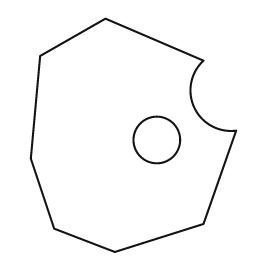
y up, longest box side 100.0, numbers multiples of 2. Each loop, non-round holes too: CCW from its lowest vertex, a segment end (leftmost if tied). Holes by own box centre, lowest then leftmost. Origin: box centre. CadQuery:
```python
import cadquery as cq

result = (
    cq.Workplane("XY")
    .moveTo(-8.0, -50.0)
    .lineTo(30.0, -38.0)
    .lineTo(44.0, 2.0)
    .threePointArc((26.0, 12.0), (30.0, 32.0))
    .lineTo(-12.0, 50.0)
    .lineTo(-40.0, 34.0)
    .lineTo(-44.0, -10.0)
    .lineTo(-34.0, -40.0)
    .close()
    .moveTo(10.0, -2.0)
    .circle(10.0)
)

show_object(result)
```